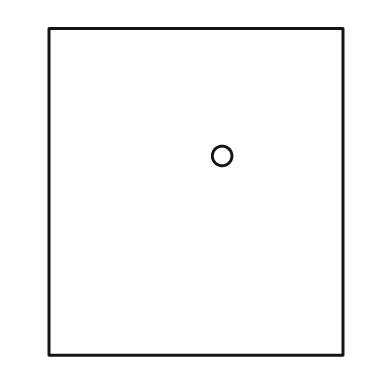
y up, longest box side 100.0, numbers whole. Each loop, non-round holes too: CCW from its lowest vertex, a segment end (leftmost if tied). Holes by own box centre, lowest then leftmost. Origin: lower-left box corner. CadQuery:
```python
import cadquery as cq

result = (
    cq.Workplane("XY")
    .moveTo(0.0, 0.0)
    .lineTo(90.0, 0.0)
    .lineTo(90.0, 100.0)
    .lineTo(0.0, 100.0)
    .close()
    .moveTo(53.0, 61.0)
    .circle(3.0)
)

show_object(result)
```